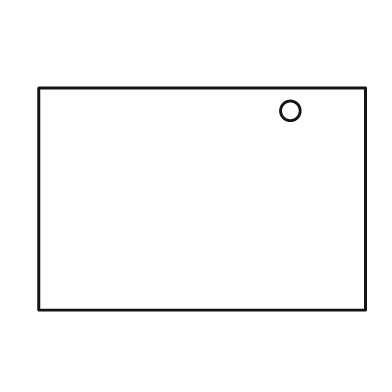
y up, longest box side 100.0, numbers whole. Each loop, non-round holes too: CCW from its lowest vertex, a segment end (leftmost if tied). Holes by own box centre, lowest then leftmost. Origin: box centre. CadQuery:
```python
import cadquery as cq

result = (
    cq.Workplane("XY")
    .moveTo(-50.0, -34.0)
    .lineTo(50.0, -34.0)
    .lineTo(50.0, 34.0)
    .lineTo(-50.0, 34.0)
    .close()
    .moveTo(27.0, 27.0)
    .circle(3.0)
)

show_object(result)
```